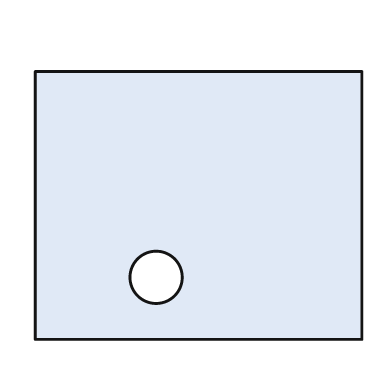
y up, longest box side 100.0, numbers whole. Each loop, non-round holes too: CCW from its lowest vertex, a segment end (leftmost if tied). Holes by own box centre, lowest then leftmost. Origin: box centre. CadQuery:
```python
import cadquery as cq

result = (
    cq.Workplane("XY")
    .moveTo(-50.0, -41.0)
    .lineTo(50.0, -41.0)
    .lineTo(50.0, 41.0)
    .lineTo(-50.0, 41.0)
    .close()
    .moveTo(-13.0, -22.0)
    .circle(8.0)
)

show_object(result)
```